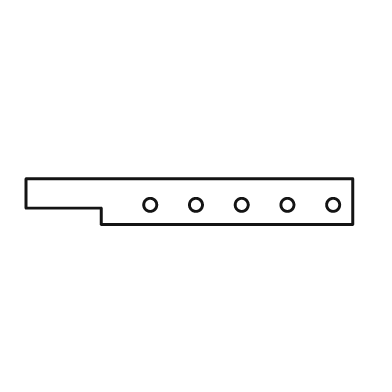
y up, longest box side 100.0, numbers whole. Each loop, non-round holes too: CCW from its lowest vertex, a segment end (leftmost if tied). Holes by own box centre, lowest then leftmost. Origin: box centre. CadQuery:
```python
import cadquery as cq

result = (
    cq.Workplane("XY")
    .moveTo(-27.0, -7.0)
    .lineTo(50.0, -7.0)
    .lineTo(50.0, 7.0)
    .lineTo(-50.0, 7.0)
    .lineTo(-50.0, -2.0)
    .lineTo(-27.0, -2.0)
    .close()
    .moveTo(-12.0, -1.0)
    .circle(2.0)
    .moveTo(2.0, -1.0)
    .circle(2.0)
    .moveTo(16.0, -1.0)
    .circle(2.0)
    .moveTo(30.0, -1.0)
    .circle(2.0)
    .moveTo(44.0, -1.0)
    .circle(2.0)
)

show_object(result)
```